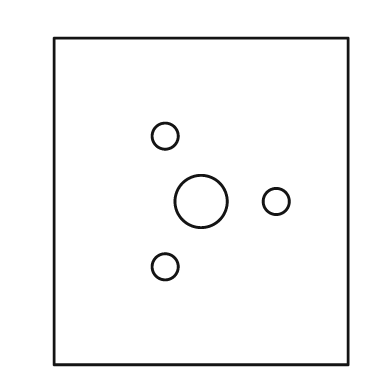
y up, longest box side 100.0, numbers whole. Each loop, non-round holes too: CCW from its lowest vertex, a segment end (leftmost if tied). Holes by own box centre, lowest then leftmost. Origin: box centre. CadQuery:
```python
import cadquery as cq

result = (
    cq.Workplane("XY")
    .moveTo(-45.0, -50.0)
    .lineTo(45.0, -50.0)
    .lineTo(45.0, 50.0)
    .lineTo(-45.0, 50.0)
    .close()
    .moveTo(-11.0, -20.0)
    .circle(4.0)
    .moveTo(0.0, 0.0)
    .circle(8.0)
    .moveTo(23.0, 0.0)
    .circle(4.0)
    .moveTo(-11.0, 20.0)
    .circle(4.0)
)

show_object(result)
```